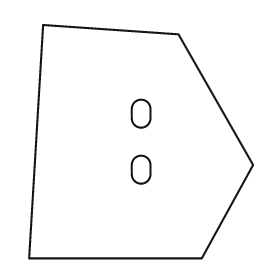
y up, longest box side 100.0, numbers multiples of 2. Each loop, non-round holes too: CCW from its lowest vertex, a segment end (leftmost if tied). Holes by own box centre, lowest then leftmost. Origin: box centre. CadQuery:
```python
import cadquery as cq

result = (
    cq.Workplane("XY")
    .moveTo(-48.0, -50.0)
    .lineTo(26.0, -50.0)
    .lineTo(48.0, -10.0)
    .lineTo(16.0, 46.0)
    .lineTo(-42.0, 50.0)
    .close()
    .moveTo(-4.0, -14.0)
    .threePointArc((0.0, -18.0), (4.0, -14.0))
    .lineTo(4.0, -10.0)
    .threePointArc((0.0, -6.0), (-4.0, -10.0))
    .close()
    .moveTo(-4.0, 10.0)
    .threePointArc((0.0, 6.0), (4.0, 10.0))
    .lineTo(4.0, 14.0)
    .threePointArc((0.0, 18.0), (-4.0, 14.0))
    .close()
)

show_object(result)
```